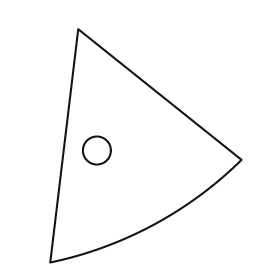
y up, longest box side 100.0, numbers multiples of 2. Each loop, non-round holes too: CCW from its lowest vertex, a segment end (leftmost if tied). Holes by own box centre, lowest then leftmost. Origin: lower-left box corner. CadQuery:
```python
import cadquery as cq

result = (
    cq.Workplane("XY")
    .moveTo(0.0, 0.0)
    .threePointArc((44.0, 16.0), (82.0, 44.0))
    .lineTo(12.0, 100.0)
    .close()
    .moveTo(20.0, 48.0)
    .circle(6.0)
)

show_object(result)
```